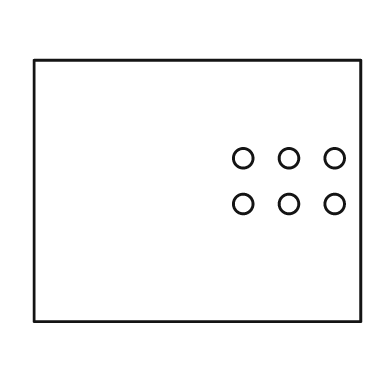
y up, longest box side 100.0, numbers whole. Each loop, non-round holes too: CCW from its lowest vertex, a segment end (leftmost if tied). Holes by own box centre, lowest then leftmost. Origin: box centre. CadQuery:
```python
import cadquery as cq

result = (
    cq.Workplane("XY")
    .moveTo(-50.0, -40.0)
    .lineTo(50.0, -40.0)
    .lineTo(50.0, 40.0)
    .lineTo(-50.0, 40.0)
    .close()
    .moveTo(14.0, -4.0)
    .circle(3.0)
    .moveTo(28.0, -4.0)
    .circle(3.0)
    .moveTo(42.0, -4.0)
    .circle(3.0)
    .moveTo(14.0, 10.0)
    .circle(3.0)
    .moveTo(28.0, 10.0)
    .circle(3.0)
    .moveTo(42.0, 10.0)
    .circle(3.0)
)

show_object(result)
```